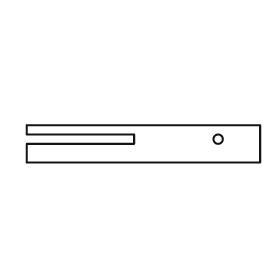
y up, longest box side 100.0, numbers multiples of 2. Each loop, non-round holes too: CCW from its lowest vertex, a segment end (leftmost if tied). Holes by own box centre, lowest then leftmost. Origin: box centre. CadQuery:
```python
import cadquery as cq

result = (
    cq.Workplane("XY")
    .moveTo(-50.0, -8.0)
    .lineTo(50.0, -8.0)
    .lineTo(50.0, 8.0)
    .lineTo(-50.0, 8.0)
    .lineTo(-50.0, 4.0)
    .lineTo(-4.0, 4.0)
    .lineTo(-4.0, 0.0)
    .lineTo(-50.0, 0.0)
    .close()
    .moveTo(32.0, 2.0)
    .circle(2.0)
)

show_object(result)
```